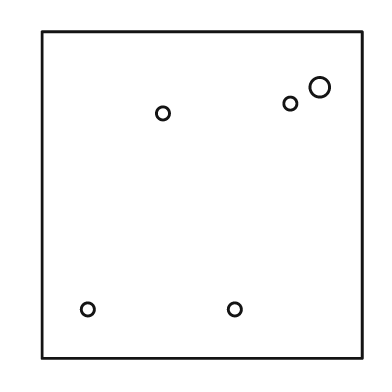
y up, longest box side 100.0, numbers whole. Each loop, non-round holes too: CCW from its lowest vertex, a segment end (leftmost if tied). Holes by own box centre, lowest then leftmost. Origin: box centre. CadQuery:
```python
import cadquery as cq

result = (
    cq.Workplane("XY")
    .moveTo(-49.0, -50.0)
    .lineTo(49.0, -50.0)
    .lineTo(49.0, 50.0)
    .lineTo(-49.0, 50.0)
    .close()
    .moveTo(-35.0, -35.0)
    .circle(2.0)
    .moveTo(10.0, -35.0)
    .circle(2.0)
    .moveTo(-12.0, 25.0)
    .circle(2.0)
    .moveTo(27.0, 28.0)
    .circle(2.0)
    .moveTo(36.0, 33.0)
    .circle(3.0)
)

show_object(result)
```